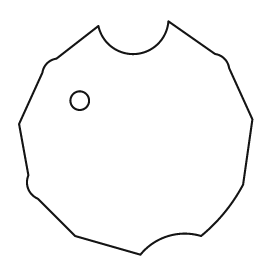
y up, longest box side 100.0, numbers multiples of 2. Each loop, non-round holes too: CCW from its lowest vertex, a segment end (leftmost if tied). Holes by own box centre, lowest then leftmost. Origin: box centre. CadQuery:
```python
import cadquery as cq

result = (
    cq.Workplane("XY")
    .moveTo(2.0, -50.0)
    .threePointArc((14.0, -42.0), (28.0, -42.0))
    .threePointArc((38.0, -32.0), (46.0, -20.0))
    .lineTo(50.0, 8.0)
    .lineTo(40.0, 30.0)
    .threePointArc((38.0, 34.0), (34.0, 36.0))
    .lineTo(14.0, 50.0)
    .threePointArc((0.0, 36.0), (-16.0, 48.0))
    .lineTo(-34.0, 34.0)
    .threePointArc((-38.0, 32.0), (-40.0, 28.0))
    .lineTo(-50.0, 6.0)
    .lineTo(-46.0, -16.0)
    .threePointArc((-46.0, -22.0), (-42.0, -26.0))
    .lineTo(-26.0, -42.0)
    .close()
    .moveTo(-24.0, 16.0)
    .circle(4.0)
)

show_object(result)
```